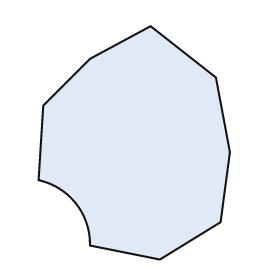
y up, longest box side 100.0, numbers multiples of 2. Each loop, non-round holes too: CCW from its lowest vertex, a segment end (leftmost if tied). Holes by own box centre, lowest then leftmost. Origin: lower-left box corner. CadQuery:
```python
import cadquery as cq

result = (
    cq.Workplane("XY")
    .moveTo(52.0, 0.0)
    .lineTo(78.0, 16.0)
    .lineTo(82.0, 46.0)
    .lineTo(76.0, 78.0)
    .lineTo(48.0, 100.0)
    .lineTo(22.0, 86.0)
    .lineTo(2.0, 66.0)
    .lineTo(0.0, 34.0)
    .threePointArc((16.0, 24.0), (22.0, 6.0))
    .close()
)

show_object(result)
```